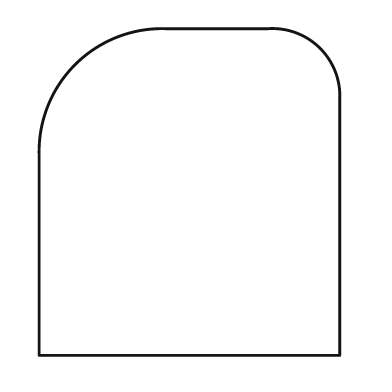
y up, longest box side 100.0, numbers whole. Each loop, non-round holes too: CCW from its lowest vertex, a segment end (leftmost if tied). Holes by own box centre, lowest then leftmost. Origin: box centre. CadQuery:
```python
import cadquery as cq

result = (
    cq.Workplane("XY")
    .moveTo(-46.0, -50.0)
    .lineTo(46.0, -50.0)
    .lineTo(46.0, 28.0)
    .threePointArc((40.0, 44.0), (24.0, 50.0))
    .lineTo(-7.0, 50.0)
    .threePointArc((-35.0, 39.0), (-46.0, 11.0))
    .close()
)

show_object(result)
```